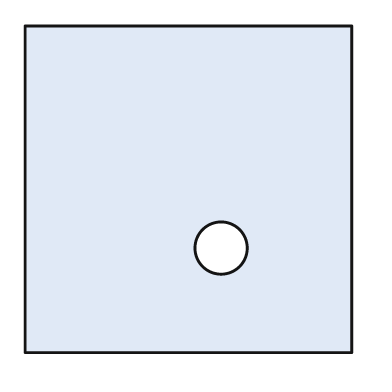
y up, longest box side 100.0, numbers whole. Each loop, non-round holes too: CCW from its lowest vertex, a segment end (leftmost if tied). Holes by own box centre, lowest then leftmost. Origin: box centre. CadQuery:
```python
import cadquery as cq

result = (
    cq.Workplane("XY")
    .moveTo(-50.0, -50.0)
    .lineTo(50.0, -50.0)
    .lineTo(50.0, 50.0)
    .lineTo(-50.0, 50.0)
    .close()
    .moveTo(10.0, -18.0)
    .circle(8.0)
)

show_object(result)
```